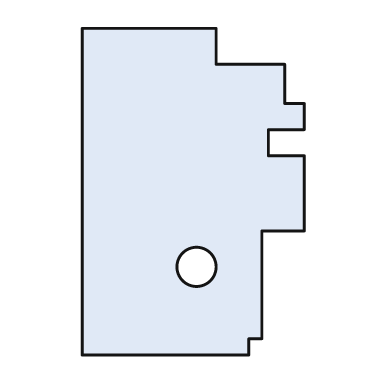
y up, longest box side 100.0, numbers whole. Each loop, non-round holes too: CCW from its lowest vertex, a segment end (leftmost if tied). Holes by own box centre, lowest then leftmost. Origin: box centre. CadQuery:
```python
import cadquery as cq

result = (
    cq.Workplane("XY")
    .moveTo(-34.0, -50.0)
    .lineTo(17.0, -50.0)
    .lineTo(17.0, -45.0)
    .lineTo(21.0, -45.0)
    .lineTo(21.0, -12.0)
    .lineTo(34.0, -12.0)
    .lineTo(34.0, 11.0)
    .lineTo(23.0, 11.0)
    .lineTo(23.0, 19.0)
    .lineTo(34.0, 19.0)
    .lineTo(34.0, 27.0)
    .lineTo(28.0, 27.0)
    .lineTo(28.0, 39.0)
    .lineTo(7.0, 39.0)
    .lineTo(7.0, 50.0)
    .lineTo(-34.0, 50.0)
    .close()
    .moveTo(1.0, -23.0)
    .circle(6.0)
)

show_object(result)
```